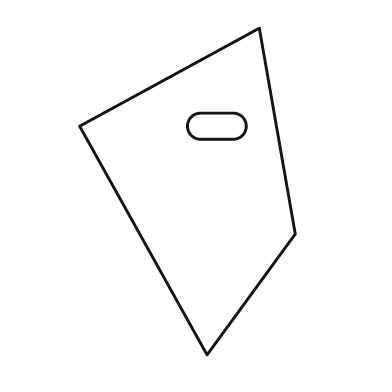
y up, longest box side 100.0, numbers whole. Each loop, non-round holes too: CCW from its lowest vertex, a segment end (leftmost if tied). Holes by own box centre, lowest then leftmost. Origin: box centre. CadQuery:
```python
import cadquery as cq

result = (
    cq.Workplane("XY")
    .moveTo(6.0, -50.0)
    .lineTo(33.0, -13.0)
    .lineTo(22.0, 50.0)
    .lineTo(-33.0, 20.0)
    .close()
    .moveTo(4.0, 16.0)
    .lineTo(14.0, 16.0)
    .threePointArc((18.0, 20.0), (14.0, 24.0))
    .lineTo(4.0, 24.0)
    .threePointArc((0.0, 20.0), (4.0, 16.0))
    .close()
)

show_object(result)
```